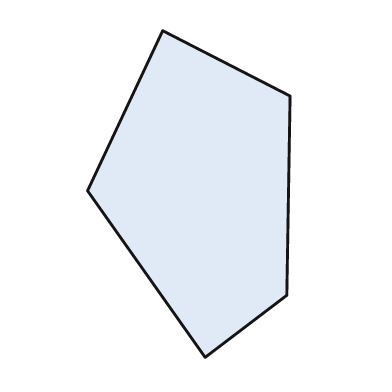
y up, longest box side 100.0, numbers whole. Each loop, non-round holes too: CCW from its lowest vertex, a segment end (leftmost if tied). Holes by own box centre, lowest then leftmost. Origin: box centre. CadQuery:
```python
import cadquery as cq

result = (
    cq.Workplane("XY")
    .moveTo(5.0, -50.0)
    .lineTo(30.0, -31.0)
    .lineTo(31.0, 30.0)
    .lineTo(-8.0, 50.0)
    .lineTo(-31.0, 1.0)
    .close()
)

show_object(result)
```